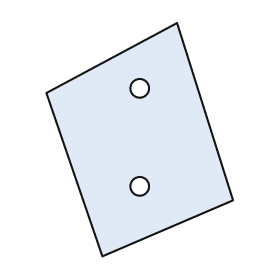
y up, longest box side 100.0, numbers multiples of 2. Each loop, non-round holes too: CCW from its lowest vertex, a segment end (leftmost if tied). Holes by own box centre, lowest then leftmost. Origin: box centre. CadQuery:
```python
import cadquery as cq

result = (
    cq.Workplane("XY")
    .moveTo(-16.0, -50.0)
    .lineTo(40.0, -26.0)
    .lineTo(16.0, 50.0)
    .lineTo(-40.0, 20.0)
    .close()
    .moveTo(0.0, -20.0)
    .circle(4.0)
    .moveTo(0.0, 22.0)
    .circle(4.0)
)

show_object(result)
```